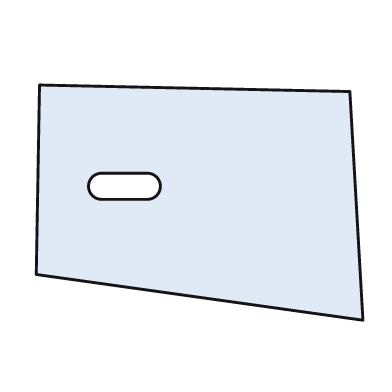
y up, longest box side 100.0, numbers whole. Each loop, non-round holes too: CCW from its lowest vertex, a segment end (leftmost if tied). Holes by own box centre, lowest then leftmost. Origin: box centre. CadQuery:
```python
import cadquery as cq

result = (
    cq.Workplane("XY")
    .moveTo(50.0, -36.0)
    .lineTo(46.0, 34.0)
    .lineTo(-49.0, 36.0)
    .lineTo(-50.0, -22.0)
    .close()
    .moveTo(-30.0, 1.0)
    .lineTo(-16.0, 1.0)
    .threePointArc((-12.0, 5.0), (-16.0, 9.0))
    .lineTo(-30.0, 9.0)
    .threePointArc((-34.0, 5.0), (-30.0, 1.0))
    .close()
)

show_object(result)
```